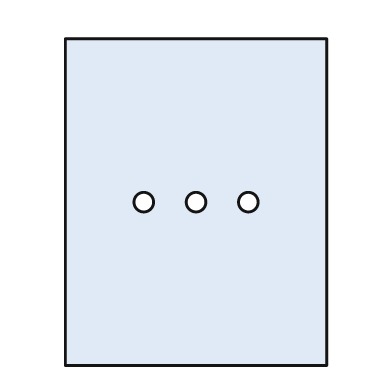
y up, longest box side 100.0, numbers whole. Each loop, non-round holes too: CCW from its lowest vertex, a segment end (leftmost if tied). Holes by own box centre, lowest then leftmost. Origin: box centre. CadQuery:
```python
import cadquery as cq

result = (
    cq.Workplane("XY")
    .moveTo(-40.0, -50.0)
    .lineTo(40.0, -50.0)
    .lineTo(40.0, 50.0)
    .lineTo(-40.0, 50.0)
    .close()
    .moveTo(-16.0, 0.0)
    .circle(3.0)
    .moveTo(0.0, 0.0)
    .circle(3.0)
    .moveTo(16.0, 0.0)
    .circle(3.0)
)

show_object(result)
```